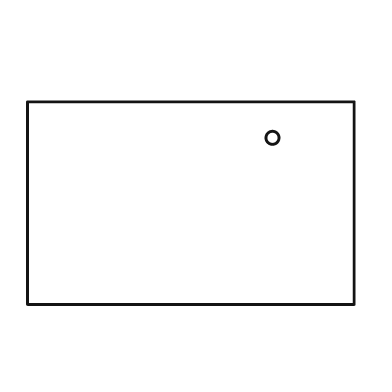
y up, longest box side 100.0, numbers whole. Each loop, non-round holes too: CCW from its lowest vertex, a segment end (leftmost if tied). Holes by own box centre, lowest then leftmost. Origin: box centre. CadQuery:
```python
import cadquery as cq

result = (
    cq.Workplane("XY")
    .moveTo(-50.0, -31.0)
    .lineTo(50.0, -31.0)
    .lineTo(50.0, 31.0)
    .lineTo(-50.0, 31.0)
    .close()
    .moveTo(25.0, 20.0)
    .circle(2.0)
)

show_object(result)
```